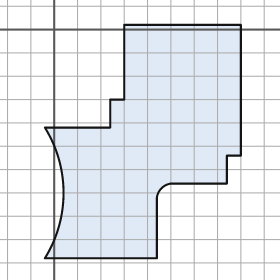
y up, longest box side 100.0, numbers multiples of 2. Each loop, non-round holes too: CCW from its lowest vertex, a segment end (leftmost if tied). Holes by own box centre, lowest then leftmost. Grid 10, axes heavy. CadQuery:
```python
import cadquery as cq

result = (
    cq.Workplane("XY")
    .moveTo(-4.0, -98.0)
    .lineTo(44.0, -98.0)
    .lineTo(44.0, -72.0)
    .threePointArc((46.0, -68.0), (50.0, -66.0))
    .lineTo(74.0, -66.0)
    .lineTo(74.0, -54.0)
    .lineTo(80.0, -54.0)
    .lineTo(80.0, 2.0)
    .lineTo(30.0, 2.0)
    .lineTo(30.0, -30.0)
    .lineTo(24.0, -30.0)
    .lineTo(24.0, -42.0)
    .lineTo(-4.0, -42.0)
    .threePointArc((4.0, -70.0), (-4.0, -98.0))
    .close()
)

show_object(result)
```